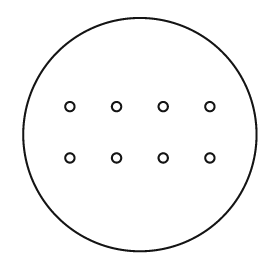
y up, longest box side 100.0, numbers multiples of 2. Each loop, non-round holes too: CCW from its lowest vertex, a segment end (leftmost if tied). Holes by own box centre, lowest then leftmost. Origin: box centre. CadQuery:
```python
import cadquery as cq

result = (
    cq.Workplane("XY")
    .moveTo(0.0, 0.0)
    .circle(50.0)
    .moveTo(-30.0, -10.0)
    .circle(2.0)
    .moveTo(-10.0, -10.0)
    .circle(2.0)
    .moveTo(10.0, -10.0)
    .circle(2.0)
    .moveTo(30.0, -10.0)
    .circle(2.0)
    .moveTo(-30.0, 12.0)
    .circle(2.0)
    .moveTo(-10.0, 12.0)
    .circle(2.0)
    .moveTo(10.0, 12.0)
    .circle(2.0)
    .moveTo(30.0, 12.0)
    .circle(2.0)
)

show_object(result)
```